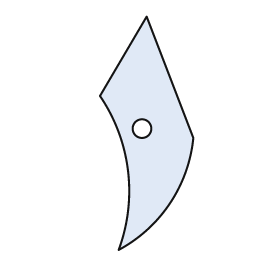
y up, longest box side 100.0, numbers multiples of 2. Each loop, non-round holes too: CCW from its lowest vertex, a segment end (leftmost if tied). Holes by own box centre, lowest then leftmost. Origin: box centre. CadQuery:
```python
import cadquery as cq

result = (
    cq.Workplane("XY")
    .moveTo(-12.0, -50.0)
    .threePointArc((10.0, -30.0), (20.0, -2.0))
    .lineTo(0.0, 50.0)
    .lineTo(-20.0, 16.0)
    .threePointArc((-8.0, -16.0), (-12.0, -50.0))
    .close()
    .moveTo(-2.0, 2.0)
    .circle(4.0)
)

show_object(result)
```